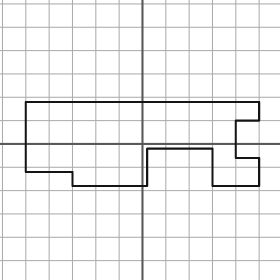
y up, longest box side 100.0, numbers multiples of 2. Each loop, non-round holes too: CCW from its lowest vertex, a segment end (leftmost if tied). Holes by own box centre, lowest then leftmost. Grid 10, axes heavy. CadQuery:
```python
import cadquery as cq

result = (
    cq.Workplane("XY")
    .moveTo(-30.0, -18.0)
    .lineTo(2.0, -18.0)
    .lineTo(2.0, -2.0)
    .lineTo(30.0, -2.0)
    .lineTo(30.0, -18.0)
    .lineTo(50.0, -18.0)
    .lineTo(50.0, -6.0)
    .lineTo(40.0, -6.0)
    .lineTo(40.0, 10.0)
    .lineTo(50.0, 10.0)
    .lineTo(50.0, 18.0)
    .lineTo(-50.0, 18.0)
    .lineTo(-50.0, -12.0)
    .lineTo(-30.0, -12.0)
    .close()
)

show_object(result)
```